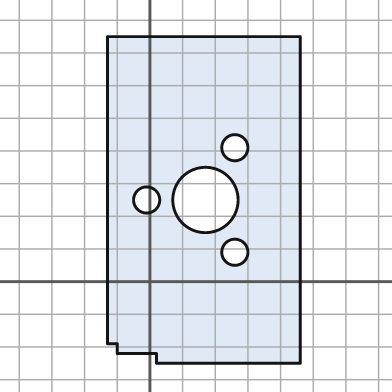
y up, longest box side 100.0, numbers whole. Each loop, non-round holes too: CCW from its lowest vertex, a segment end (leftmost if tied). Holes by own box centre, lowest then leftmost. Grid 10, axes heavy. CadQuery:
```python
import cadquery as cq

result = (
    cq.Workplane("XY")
    .moveTo(2.0, -25.0)
    .lineTo(46.0, -25.0)
    .lineTo(46.0, 75.0)
    .lineTo(-13.0, 75.0)
    .lineTo(-13.0, -19.0)
    .lineTo(-10.0, -19.0)
    .lineTo(-10.0, -22.0)
    .lineTo(2.0, -22.0)
    .close()
    .moveTo(26.0, 9.0)
    .circle(4.0)
    .moveTo(-1.0, 25.0)
    .circle(4.0)
    .moveTo(17.0, 25.0)
    .circle(10.0)
    .moveTo(26.0, 41.0)
    .circle(4.0)
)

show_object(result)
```